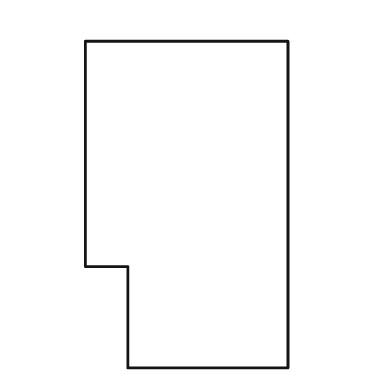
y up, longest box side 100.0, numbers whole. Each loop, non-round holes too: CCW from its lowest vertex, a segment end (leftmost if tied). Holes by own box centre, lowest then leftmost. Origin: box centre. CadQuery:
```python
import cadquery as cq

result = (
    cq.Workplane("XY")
    .moveTo(-18.0, -50.0)
    .lineTo(31.0, -50.0)
    .lineTo(31.0, 50.0)
    .lineTo(-31.0, 50.0)
    .lineTo(-31.0, -19.0)
    .lineTo(-18.0, -19.0)
    .close()
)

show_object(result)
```